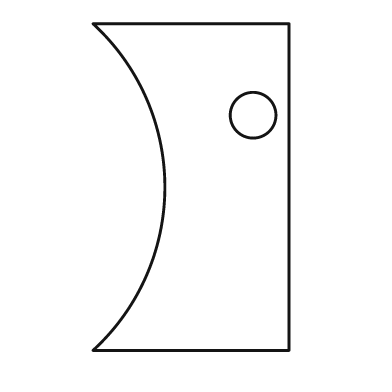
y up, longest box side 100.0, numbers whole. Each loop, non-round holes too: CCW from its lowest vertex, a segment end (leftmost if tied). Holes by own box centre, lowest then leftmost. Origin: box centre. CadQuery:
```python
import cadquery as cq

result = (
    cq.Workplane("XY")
    .moveTo(-30.0, -50.0)
    .lineTo(30.0, -50.0)
    .lineTo(30.0, 50.0)
    .lineTo(-30.0, 50.0)
    .threePointArc((-8.0, 0.0), (-30.0, -50.0))
    .close()
    .moveTo(19.0, 22.0)
    .circle(7.0)
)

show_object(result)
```